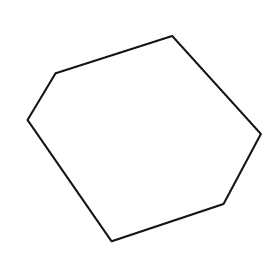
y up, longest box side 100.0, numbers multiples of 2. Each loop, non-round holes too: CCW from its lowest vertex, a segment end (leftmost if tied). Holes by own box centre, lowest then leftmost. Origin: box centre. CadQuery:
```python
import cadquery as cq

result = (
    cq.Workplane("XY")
    .moveTo(-14.0, -44.0)
    .lineTo(34.0, -28.0)
    .lineTo(50.0, 2.0)
    .lineTo(12.0, 44.0)
    .lineTo(-38.0, 28.0)
    .lineTo(-50.0, 8.0)
    .close()
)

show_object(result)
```